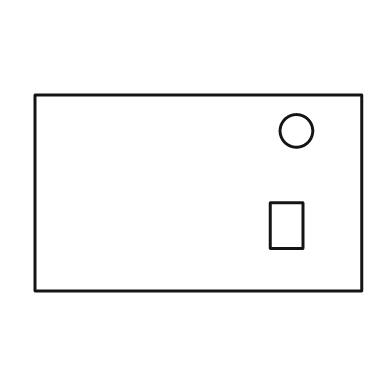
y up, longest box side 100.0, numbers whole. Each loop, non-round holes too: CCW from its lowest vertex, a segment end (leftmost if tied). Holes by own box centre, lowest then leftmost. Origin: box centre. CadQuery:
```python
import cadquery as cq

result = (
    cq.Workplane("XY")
    .moveTo(-50.0, -30.0)
    .lineTo(50.0, -30.0)
    .lineTo(50.0, 30.0)
    .lineTo(-50.0, 30.0)
    .close()
    .moveTo(22.0, -17.0)
    .lineTo(32.0, -17.0)
    .lineTo(32.0, -3.0)
    .lineTo(22.0, -3.0)
    .close()
    .moveTo(30.0, 19.0)
    .circle(5.0)
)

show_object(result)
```